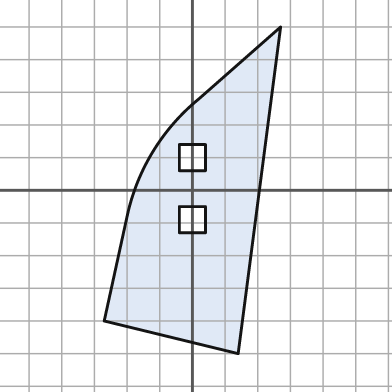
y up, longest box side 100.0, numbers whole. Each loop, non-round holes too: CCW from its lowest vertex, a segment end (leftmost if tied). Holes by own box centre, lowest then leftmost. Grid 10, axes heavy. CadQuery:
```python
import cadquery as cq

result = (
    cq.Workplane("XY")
    .moveTo(14.0, -50.0)
    .lineTo(27.0, 50.0)
    .lineTo(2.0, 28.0)
    .threePointArc((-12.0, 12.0), (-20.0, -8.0))
    .lineTo(-27.0, -40.0)
    .close()
    .moveTo(-4.0, -13.0)
    .lineTo(4.0, -13.0)
    .lineTo(4.0, -5.0)
    .lineTo(-4.0, -5.0)
    .close()
    .moveTo(-4.0, 6.0)
    .lineTo(4.0, 6.0)
    .lineTo(4.0, 14.0)
    .lineTo(-4.0, 14.0)
    .close()
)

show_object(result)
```